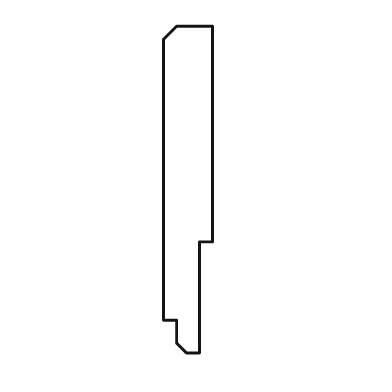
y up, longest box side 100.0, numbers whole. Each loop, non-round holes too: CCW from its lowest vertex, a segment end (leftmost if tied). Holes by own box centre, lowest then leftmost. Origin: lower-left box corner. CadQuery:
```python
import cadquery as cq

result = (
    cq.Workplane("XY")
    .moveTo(7.0, 0.0)
    .lineTo(11.0, 0.0)
    .lineTo(11.0, 34.0)
    .lineTo(15.0, 34.0)
    .lineTo(15.0, 100.0)
    .lineTo(4.0, 100.0)
    .lineTo(0.0, 96.0)
    .lineTo(0.0, 10.0)
    .lineTo(4.0, 10.0)
    .lineTo(4.0, 3.0)
    .close()
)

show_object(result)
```